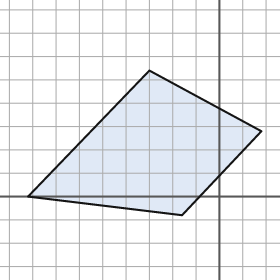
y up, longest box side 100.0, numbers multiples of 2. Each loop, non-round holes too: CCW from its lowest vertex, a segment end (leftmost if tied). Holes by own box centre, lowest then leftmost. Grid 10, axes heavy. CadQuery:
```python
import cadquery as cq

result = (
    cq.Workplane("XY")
    .moveTo(-16.0, -8.0)
    .lineTo(18.0, 28.0)
    .lineTo(-30.0, 54.0)
    .lineTo(-82.0, 0.0)
    .close()
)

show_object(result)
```